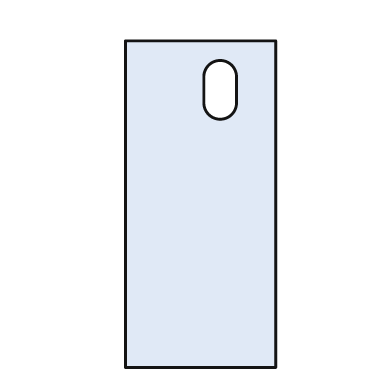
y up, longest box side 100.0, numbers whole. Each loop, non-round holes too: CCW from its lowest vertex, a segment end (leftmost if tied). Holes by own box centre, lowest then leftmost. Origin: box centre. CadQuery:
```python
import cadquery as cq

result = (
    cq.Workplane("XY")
    .moveTo(-23.0, -50.0)
    .lineTo(23.0, -50.0)
    .lineTo(23.0, 50.0)
    .lineTo(-23.0, 50.0)
    .close()
    .moveTo(1.0, 31.0)
    .threePointArc((6.0, 26.0), (11.0, 31.0))
    .lineTo(11.0, 39.0)
    .threePointArc((6.0, 44.0), (1.0, 39.0))
    .close()
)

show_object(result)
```